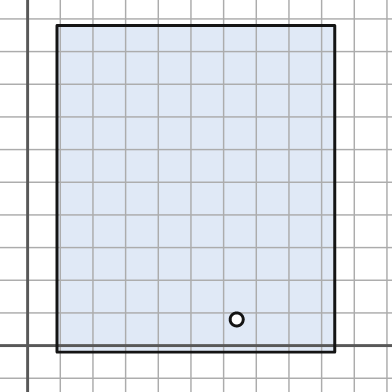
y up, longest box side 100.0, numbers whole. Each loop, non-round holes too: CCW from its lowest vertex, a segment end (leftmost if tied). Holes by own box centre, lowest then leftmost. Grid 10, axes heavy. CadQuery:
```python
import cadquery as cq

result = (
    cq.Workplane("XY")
    .moveTo(9.0, -2.0)
    .lineTo(94.0, -2.0)
    .lineTo(94.0, 98.0)
    .lineTo(9.0, 98.0)
    .close()
    .moveTo(64.0, 8.0)
    .circle(2.0)
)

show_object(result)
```